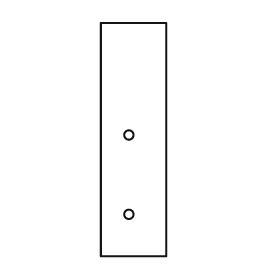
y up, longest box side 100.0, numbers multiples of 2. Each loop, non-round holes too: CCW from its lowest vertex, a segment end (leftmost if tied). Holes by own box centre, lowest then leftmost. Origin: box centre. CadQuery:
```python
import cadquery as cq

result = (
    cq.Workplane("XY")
    .moveTo(-14.0, -50.0)
    .lineTo(14.0, -50.0)
    .lineTo(14.0, 50.0)
    .lineTo(-14.0, 50.0)
    .close()
    .moveTo(-2.0, -32.0)
    .circle(2.0)
    .moveTo(-2.0, 2.0)
    .circle(2.0)
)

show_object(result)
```